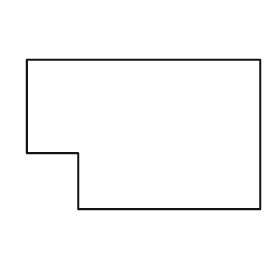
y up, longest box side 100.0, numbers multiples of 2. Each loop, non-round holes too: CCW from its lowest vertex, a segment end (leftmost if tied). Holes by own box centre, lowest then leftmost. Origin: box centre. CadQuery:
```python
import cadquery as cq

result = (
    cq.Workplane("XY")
    .moveTo(-28.0, -32.0)
    .lineTo(50.0, -32.0)
    .lineTo(50.0, 32.0)
    .lineTo(-50.0, 32.0)
    .lineTo(-50.0, -8.0)
    .lineTo(-28.0, -8.0)
    .close()
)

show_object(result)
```